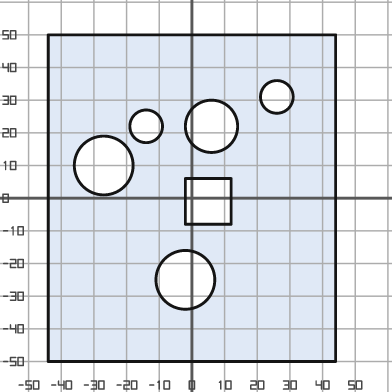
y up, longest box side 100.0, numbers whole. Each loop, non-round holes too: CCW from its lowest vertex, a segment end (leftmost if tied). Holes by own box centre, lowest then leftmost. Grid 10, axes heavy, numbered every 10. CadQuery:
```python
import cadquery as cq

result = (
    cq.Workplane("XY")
    .moveTo(-44.0, -50.0)
    .lineTo(44.0, -50.0)
    .lineTo(44.0, 50.0)
    .lineTo(-44.0, 50.0)
    .close()
    .moveTo(-2.0, -25.0)
    .circle(9.0)
    .moveTo(-2.0, -8.0)
    .lineTo(12.0, -8.0)
    .lineTo(12.0, 6.0)
    .lineTo(-2.0, 6.0)
    .close()
    .moveTo(-27.0, 10.0)
    .circle(9.0)
    .moveTo(-14.0, 22.0)
    .circle(5.0)
    .moveTo(6.0, 22.0)
    .circle(8.0)
    .moveTo(26.0, 31.0)
    .circle(5.0)
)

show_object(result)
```